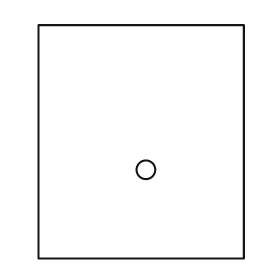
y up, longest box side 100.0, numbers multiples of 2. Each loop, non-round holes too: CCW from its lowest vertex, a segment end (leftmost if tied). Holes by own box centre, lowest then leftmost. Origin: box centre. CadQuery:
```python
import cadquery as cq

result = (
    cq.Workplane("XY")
    .moveTo(-44.0, -50.0)
    .lineTo(44.0, -50.0)
    .lineTo(44.0, 50.0)
    .lineTo(-44.0, 50.0)
    .close()
    .moveTo(2.0, -12.0)
    .circle(4.0)
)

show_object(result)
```